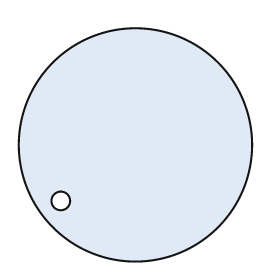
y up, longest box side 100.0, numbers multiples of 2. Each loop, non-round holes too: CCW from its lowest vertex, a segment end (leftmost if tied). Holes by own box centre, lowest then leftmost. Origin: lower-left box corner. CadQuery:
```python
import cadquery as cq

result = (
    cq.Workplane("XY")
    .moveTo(50.0, 50.0)
    .circle(50.0)
    .moveTo(18.0, 26.0)
    .circle(4.0)
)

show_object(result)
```